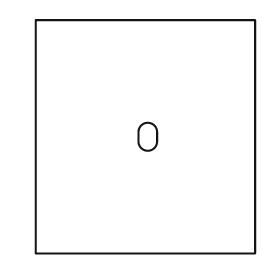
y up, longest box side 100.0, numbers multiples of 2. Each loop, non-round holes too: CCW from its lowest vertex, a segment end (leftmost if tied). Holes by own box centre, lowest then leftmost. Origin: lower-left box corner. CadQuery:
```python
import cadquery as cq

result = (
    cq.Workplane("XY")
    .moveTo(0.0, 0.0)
    .lineTo(94.0, 0.0)
    .lineTo(94.0, 100.0)
    .lineTo(0.0, 100.0)
    .close()
    .moveTo(44.0, 48.0)
    .threePointArc((48.0, 44.0), (52.0, 48.0))
    .lineTo(52.0, 52.0)
    .threePointArc((48.0, 56.0), (44.0, 52.0))
    .close()
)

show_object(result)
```